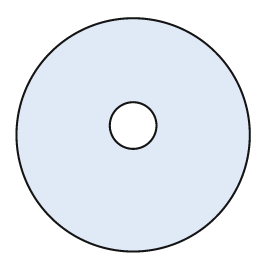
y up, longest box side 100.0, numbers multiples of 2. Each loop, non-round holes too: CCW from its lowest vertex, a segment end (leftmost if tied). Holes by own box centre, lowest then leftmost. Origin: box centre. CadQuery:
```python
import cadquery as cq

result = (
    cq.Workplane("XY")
    .moveTo(0.0, 0.0)
    .circle(50.0)
    .moveTo(0.0, 4.0)
    .circle(10.0)
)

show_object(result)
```